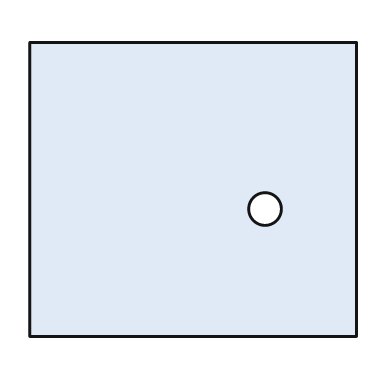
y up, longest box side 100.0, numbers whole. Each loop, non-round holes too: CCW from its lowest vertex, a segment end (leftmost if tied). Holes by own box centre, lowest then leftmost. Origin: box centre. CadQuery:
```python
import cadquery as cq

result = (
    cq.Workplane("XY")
    .moveTo(-50.0, -45.0)
    .lineTo(50.0, -45.0)
    .lineTo(50.0, 45.0)
    .lineTo(-50.0, 45.0)
    .close()
    .moveTo(22.0, -6.0)
    .circle(5.0)
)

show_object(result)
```